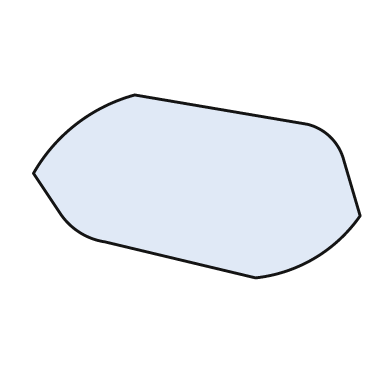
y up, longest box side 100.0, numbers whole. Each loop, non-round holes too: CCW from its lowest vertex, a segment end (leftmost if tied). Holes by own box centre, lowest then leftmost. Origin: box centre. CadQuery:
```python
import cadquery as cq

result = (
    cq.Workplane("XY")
    .moveTo(18.0, -28.0)
    .threePointArc((36.0, -22.0), (50.0, -9.0))
    .lineTo(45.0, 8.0)
    .threePointArc((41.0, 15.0), (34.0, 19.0))
    .lineTo(-19.0, 28.0)
    .threePointArc((-37.0, 19.0), (-50.0, 4.0))
    .lineTo(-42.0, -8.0)
    .threePointArc((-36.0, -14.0), (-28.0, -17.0))
    .close()
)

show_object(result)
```